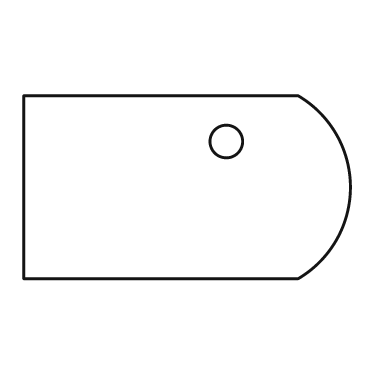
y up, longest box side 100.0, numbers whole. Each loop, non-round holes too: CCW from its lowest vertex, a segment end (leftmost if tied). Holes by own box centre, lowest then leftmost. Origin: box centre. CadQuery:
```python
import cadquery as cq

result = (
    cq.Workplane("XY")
    .moveTo(-50.0, -28.0)
    .lineTo(34.0, -28.0)
    .threePointArc((50.0, 0.0), (34.0, 28.0))
    .lineTo(-50.0, 28.0)
    .close()
    .moveTo(12.0, 14.0)
    .circle(5.0)
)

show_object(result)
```